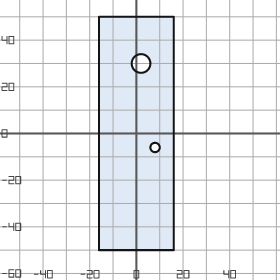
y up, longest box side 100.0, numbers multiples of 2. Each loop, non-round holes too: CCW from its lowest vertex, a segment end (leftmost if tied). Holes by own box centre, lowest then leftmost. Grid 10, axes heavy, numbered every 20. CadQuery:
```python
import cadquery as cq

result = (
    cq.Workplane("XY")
    .moveTo(-16.0, -50.0)
    .lineTo(16.0, -50.0)
    .lineTo(16.0, 50.0)
    .lineTo(-16.0, 50.0)
    .close()
    .moveTo(8.0, -6.0)
    .circle(2.0)
    .moveTo(2.0, 30.0)
    .circle(4.0)
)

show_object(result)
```